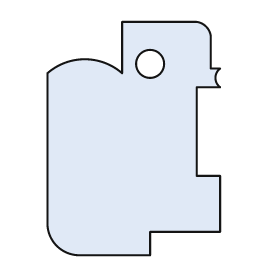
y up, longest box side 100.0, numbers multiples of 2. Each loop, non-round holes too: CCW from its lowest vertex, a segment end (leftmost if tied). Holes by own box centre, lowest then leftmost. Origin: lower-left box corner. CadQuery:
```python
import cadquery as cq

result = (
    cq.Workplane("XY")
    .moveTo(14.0, 0.0)
    .lineTo(44.0, 0.0)
    .lineTo(44.0, 10.0)
    .lineTo(74.0, 10.0)
    .lineTo(74.0, 34.0)
    .lineTo(64.0, 34.0)
    .lineTo(64.0, 72.0)
    .lineTo(74.0, 72.0)
    .threePointArc((72.0, 76.0), (74.0, 80.0))
    .lineTo(70.0, 80.0)
    .lineTo(70.0, 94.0)
    .threePointArc((68.0, 98.0), (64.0, 100.0))
    .lineTo(32.0, 100.0)
    .lineTo(32.0, 78.0)
    .threePointArc((16.0, 84.0), (0.0, 78.0))
    .lineTo(0.0, 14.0)
    .threePointArc((4.0, 4.0), (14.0, 0.0))
    .close()
    .moveTo(44.0, 82.0)
    .circle(6.0)
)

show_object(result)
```